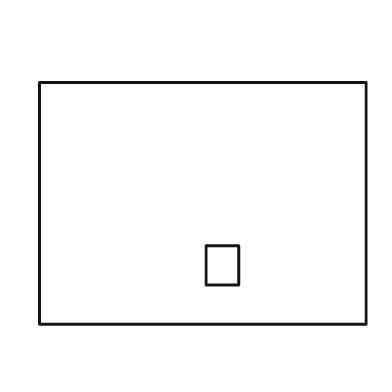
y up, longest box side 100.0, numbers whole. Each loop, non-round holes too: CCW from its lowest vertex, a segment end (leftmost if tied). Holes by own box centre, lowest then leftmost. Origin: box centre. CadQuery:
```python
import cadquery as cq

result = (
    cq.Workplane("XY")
    .moveTo(-50.0, -37.0)
    .lineTo(50.0, -37.0)
    .lineTo(50.0, 37.0)
    .lineTo(-50.0, 37.0)
    .close()
    .moveTo(1.0, -25.0)
    .lineTo(11.0, -25.0)
    .lineTo(11.0, -13.0)
    .lineTo(1.0, -13.0)
    .close()
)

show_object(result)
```